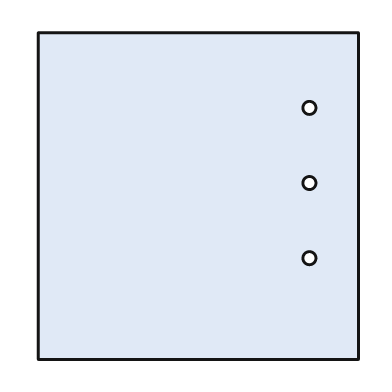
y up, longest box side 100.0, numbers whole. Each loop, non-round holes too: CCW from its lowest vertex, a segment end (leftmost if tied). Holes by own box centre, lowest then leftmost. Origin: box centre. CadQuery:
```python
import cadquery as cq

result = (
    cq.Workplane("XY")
    .moveTo(-49.0, -50.0)
    .lineTo(49.0, -50.0)
    .lineTo(49.0, 50.0)
    .lineTo(-49.0, 50.0)
    .close()
    .moveTo(34.0, -19.0)
    .circle(2.0)
    .moveTo(34.0, 4.0)
    .circle(2.0)
    .moveTo(34.0, 27.0)
    .circle(2.0)
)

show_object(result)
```